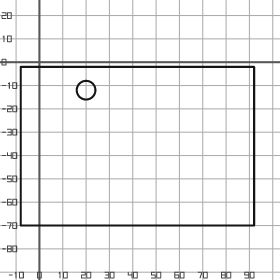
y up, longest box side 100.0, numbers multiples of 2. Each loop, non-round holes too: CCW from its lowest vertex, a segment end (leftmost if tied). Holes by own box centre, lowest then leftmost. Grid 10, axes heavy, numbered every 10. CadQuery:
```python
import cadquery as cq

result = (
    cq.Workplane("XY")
    .moveTo(-8.0, -70.0)
    .lineTo(92.0, -70.0)
    .lineTo(92.0, -2.0)
    .lineTo(-8.0, -2.0)
    .close()
    .moveTo(20.0, -12.0)
    .circle(4.0)
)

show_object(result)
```